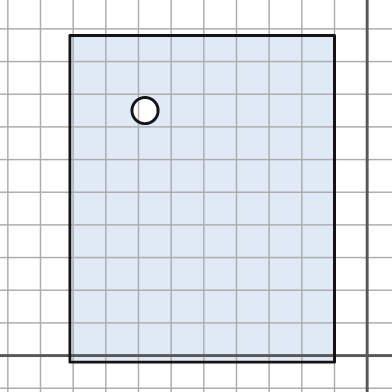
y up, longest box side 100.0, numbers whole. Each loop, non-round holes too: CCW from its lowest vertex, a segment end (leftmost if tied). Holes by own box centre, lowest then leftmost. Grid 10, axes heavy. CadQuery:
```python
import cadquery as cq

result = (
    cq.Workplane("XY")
    .moveTo(-91.0, -2.0)
    .lineTo(-10.0, -2.0)
    .lineTo(-10.0, 98.0)
    .lineTo(-91.0, 98.0)
    .close()
    .moveTo(-68.0, 75.0)
    .circle(4.0)
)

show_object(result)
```